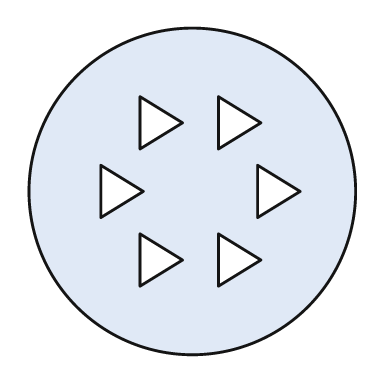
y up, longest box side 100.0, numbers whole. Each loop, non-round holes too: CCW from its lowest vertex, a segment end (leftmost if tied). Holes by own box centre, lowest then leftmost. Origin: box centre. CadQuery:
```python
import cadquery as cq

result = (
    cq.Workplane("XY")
    .moveTo(0.0, 0.0)
    .circle(50.0)
    .moveTo(-16.0, -29.0)
    .lineTo(-3.0, -21.0)
    .lineTo(-16.0, -13.0)
    .close()
    .moveTo(8.0, -29.0)
    .lineTo(21.0, -21.0)
    .lineTo(8.0, -13.0)
    .close()
    .moveTo(-28.0, -8.0)
    .lineTo(-15.0, 0.0)
    .lineTo(-28.0, 8.0)
    .close()
    .moveTo(20.0, -8.0)
    .lineTo(33.0, 0.0)
    .lineTo(20.0, 8.0)
    .close()
    .moveTo(-16.0, 13.0)
    .lineTo(-3.0, 21.0)
    .lineTo(-16.0, 29.0)
    .close()
    .moveTo(8.0, 13.0)
    .lineTo(21.0, 21.0)
    .lineTo(8.0, 29.0)
    .close()
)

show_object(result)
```